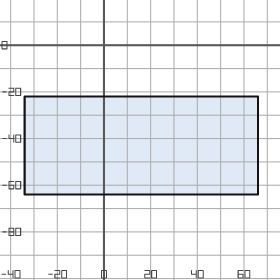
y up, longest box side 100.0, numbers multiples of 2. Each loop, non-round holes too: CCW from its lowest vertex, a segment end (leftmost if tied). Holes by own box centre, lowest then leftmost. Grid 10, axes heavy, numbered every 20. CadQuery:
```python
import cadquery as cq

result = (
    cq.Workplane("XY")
    .moveTo(-34.0, -64.0)
    .lineTo(66.0, -64.0)
    .lineTo(66.0, -22.0)
    .lineTo(-34.0, -22.0)
    .close()
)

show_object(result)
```